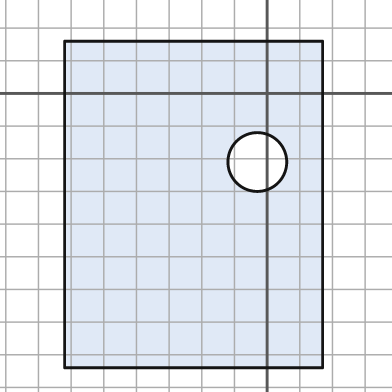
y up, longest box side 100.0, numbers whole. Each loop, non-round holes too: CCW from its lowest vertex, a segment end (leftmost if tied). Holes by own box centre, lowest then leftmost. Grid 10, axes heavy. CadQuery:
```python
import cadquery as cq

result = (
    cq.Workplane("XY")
    .moveTo(-62.0, -84.0)
    .lineTo(17.0, -84.0)
    .lineTo(17.0, 16.0)
    .lineTo(-62.0, 16.0)
    .close()
    .moveTo(-3.0, -21.0)
    .circle(9.0)
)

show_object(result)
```